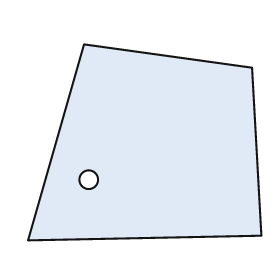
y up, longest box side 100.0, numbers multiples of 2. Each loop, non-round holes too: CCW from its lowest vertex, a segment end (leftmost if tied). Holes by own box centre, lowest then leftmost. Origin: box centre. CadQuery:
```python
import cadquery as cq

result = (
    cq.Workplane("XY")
    .moveTo(-50.0, -42.0)
    .lineTo(50.0, -40.0)
    .lineTo(46.0, 32.0)
    .lineTo(-26.0, 42.0)
    .close()
    .moveTo(-24.0, -16.0)
    .circle(4.0)
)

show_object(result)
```